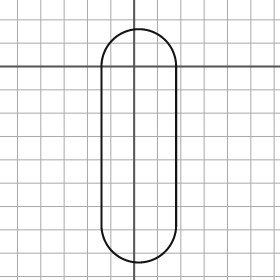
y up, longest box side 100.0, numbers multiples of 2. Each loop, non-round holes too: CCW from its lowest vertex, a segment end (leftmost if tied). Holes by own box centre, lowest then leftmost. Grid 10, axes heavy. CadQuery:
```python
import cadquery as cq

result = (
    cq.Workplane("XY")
    .moveTo(-14.0, -68.0)
    .threePointArc((2.0, -84.0), (18.0, -68.0))
    .lineTo(18.0, 0.0)
    .threePointArc((2.0, 16.0), (-14.0, 0.0))
    .close()
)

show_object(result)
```